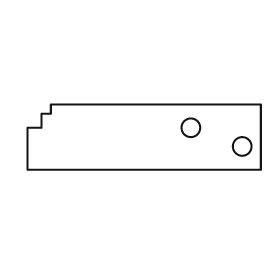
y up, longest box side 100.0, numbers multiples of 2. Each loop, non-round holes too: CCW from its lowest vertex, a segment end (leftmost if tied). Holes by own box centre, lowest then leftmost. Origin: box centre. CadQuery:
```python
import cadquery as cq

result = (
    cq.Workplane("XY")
    .moveTo(-50.0, -14.0)
    .lineTo(50.0, -14.0)
    .lineTo(50.0, 14.0)
    .lineTo(-40.0, 14.0)
    .lineTo(-40.0, 10.0)
    .lineTo(-44.0, 10.0)
    .lineTo(-44.0, 4.0)
    .lineTo(-50.0, 4.0)
    .close()
    .moveTo(42.0, -4.0)
    .circle(4.0)
    .moveTo(20.0, 4.0)
    .circle(4.0)
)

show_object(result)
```